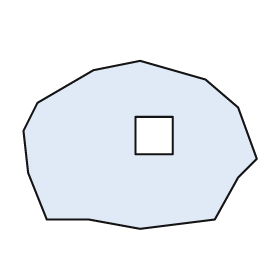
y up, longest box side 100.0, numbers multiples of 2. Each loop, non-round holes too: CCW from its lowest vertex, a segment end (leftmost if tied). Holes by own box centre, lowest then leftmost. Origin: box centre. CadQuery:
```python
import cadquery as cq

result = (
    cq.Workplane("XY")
    .moveTo(0.0, -36.0)
    .lineTo(32.0, -32.0)
    .lineTo(42.0, -14.0)
    .lineTo(50.0, -6.0)
    .lineTo(42.0, 16.0)
    .lineTo(28.0, 28.0)
    .lineTo(0.0, 36.0)
    .lineTo(-20.0, 32.0)
    .lineTo(-44.0, 18.0)
    .lineTo(-50.0, 6.0)
    .lineTo(-48.0, -12.0)
    .lineTo(-40.0, -32.0)
    .lineTo(-22.0, -32.0)
    .close()
    .moveTo(-2.0, -4.0)
    .lineTo(14.0, -4.0)
    .lineTo(14.0, 12.0)
    .lineTo(-2.0, 12.0)
    .close()
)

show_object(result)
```